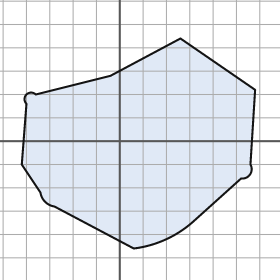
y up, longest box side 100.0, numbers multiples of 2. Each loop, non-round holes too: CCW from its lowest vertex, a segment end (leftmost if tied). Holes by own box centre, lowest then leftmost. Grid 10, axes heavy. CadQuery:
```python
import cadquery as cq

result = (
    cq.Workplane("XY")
    .moveTo(6.0, -46.0)
    .threePointArc((20.0, -42.0), (32.0, -34.0))
    .lineTo(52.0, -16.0)
    .threePointArc((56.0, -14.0), (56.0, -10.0))
    .lineTo(58.0, 22.0)
    .lineTo(26.0, 44.0)
    .lineTo(-4.0, 28.0)
    .lineTo(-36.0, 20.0)
    .threePointArc((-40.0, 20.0), (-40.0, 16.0))
    .lineTo(-42.0, -10.0)
    .lineTo(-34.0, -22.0)
    .threePointArc((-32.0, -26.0), (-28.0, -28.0))
    .close()
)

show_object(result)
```